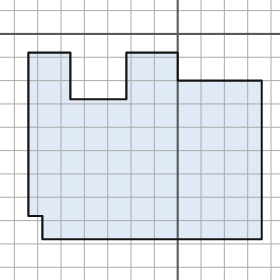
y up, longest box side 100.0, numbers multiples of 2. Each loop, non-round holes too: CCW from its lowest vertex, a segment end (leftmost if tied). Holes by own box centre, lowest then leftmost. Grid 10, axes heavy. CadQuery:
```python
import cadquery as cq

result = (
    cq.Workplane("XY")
    .moveTo(-58.0, -88.0)
    .lineTo(36.0, -88.0)
    .lineTo(36.0, -20.0)
    .lineTo(0.0, -20.0)
    .lineTo(0.0, -8.0)
    .lineTo(-22.0, -8.0)
    .lineTo(-22.0, -28.0)
    .lineTo(-46.0, -28.0)
    .lineTo(-46.0, -8.0)
    .lineTo(-64.0, -8.0)
    .lineTo(-64.0, -78.0)
    .lineTo(-58.0, -78.0)
    .close()
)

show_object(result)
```